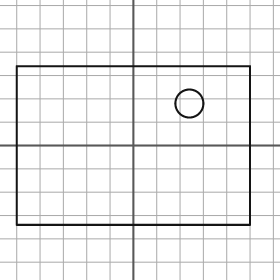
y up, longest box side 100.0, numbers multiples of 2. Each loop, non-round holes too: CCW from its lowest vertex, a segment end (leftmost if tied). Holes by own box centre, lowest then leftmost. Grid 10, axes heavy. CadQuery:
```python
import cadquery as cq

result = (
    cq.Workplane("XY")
    .moveTo(-50.0, -34.0)
    .lineTo(50.0, -34.0)
    .lineTo(50.0, 34.0)
    .lineTo(-50.0, 34.0)
    .close()
    .moveTo(24.0, 18.0)
    .circle(6.0)
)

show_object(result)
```